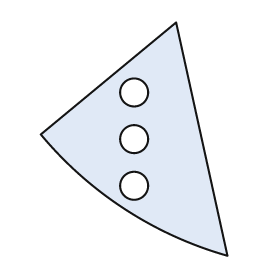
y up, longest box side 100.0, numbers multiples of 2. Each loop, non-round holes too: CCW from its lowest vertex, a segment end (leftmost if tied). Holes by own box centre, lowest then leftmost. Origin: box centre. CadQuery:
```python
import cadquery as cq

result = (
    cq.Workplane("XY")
    .moveTo(40.0, -50.0)
    .lineTo(18.0, 50.0)
    .lineTo(-40.0, 2.0)
    .threePointArc((-4.0, -30.0), (40.0, -50.0))
    .close()
    .moveTo(0.0, -20.0)
    .circle(6.0)
    .moveTo(0.0, 0.0)
    .circle(6.0)
    .moveTo(0.0, 20.0)
    .circle(6.0)
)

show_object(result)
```